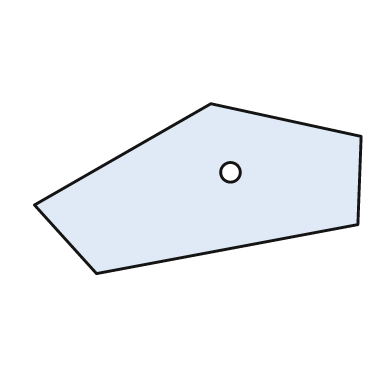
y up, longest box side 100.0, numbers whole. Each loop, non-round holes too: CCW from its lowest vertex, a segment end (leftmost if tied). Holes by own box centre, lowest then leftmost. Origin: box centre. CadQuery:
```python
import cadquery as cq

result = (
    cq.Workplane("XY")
    .moveTo(-31.0, -26.0)
    .lineTo(49.0, -11.0)
    .lineTo(50.0, 16.0)
    .lineTo(4.0, 26.0)
    .lineTo(-50.0, -5.0)
    .close()
    .moveTo(10.0, 5.0)
    .circle(3.0)
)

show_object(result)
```